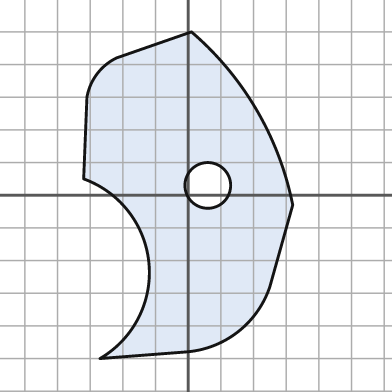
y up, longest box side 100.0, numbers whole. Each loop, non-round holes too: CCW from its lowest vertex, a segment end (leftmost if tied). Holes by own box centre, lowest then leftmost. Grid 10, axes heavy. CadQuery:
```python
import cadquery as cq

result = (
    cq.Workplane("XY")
    .moveTo(-27.0, -50.0)
    .lineTo(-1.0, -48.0)
    .threePointArc((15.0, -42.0), (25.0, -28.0))
    .lineTo(32.0, -3.0)
    .threePointArc((21.0, 26.0), (1.0, 50.0))
    .lineTo(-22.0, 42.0)
    .threePointArc((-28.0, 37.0), (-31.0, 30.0))
    .lineTo(-32.0, 5.0)
    .threePointArc((-12.0, -21.0), (-27.0, -50.0))
    .close()
    .moveTo(6.0, 3.0)
    .circle(7.0)
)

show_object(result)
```